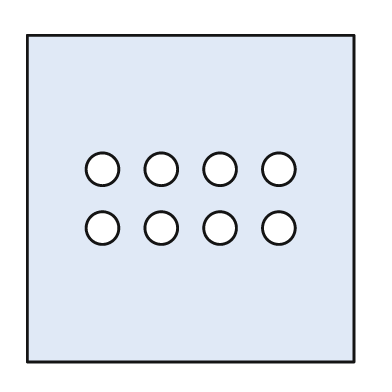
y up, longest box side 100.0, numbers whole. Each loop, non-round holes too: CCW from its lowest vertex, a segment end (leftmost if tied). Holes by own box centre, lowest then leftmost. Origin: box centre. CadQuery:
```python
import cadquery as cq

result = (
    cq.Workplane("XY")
    .moveTo(-50.0, -50.0)
    .lineTo(50.0, -50.0)
    .lineTo(50.0, 50.0)
    .lineTo(-50.0, 50.0)
    .close()
    .moveTo(-27.0, -9.0)
    .circle(5.0)
    .moveTo(-9.0, -9.0)
    .circle(5.0)
    .moveTo(9.0, -9.0)
    .circle(5.0)
    .moveTo(27.0, -9.0)
    .circle(5.0)
    .moveTo(-27.0, 9.0)
    .circle(5.0)
    .moveTo(-9.0, 9.0)
    .circle(5.0)
    .moveTo(9.0, 9.0)
    .circle(5.0)
    .moveTo(27.0, 9.0)
    .circle(5.0)
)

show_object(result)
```